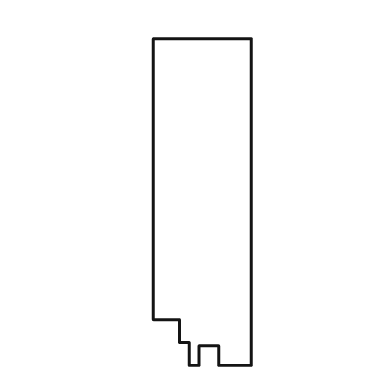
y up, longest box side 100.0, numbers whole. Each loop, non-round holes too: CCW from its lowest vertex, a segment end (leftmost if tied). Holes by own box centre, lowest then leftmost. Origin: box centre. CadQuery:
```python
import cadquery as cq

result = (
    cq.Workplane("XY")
    .moveTo(-4.0, -50.0)
    .lineTo(-1.0, -50.0)
    .lineTo(-1.0, -44.0)
    .lineTo(5.0, -44.0)
    .lineTo(5.0, -50.0)
    .lineTo(15.0, -50.0)
    .lineTo(15.0, 50.0)
    .lineTo(-15.0, 50.0)
    .lineTo(-15.0, -36.0)
    .lineTo(-7.0, -36.0)
    .lineTo(-7.0, -43.0)
    .lineTo(-4.0, -43.0)
    .close()
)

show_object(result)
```